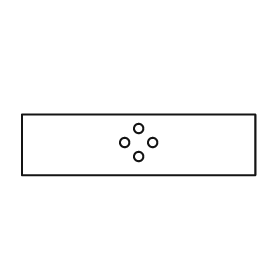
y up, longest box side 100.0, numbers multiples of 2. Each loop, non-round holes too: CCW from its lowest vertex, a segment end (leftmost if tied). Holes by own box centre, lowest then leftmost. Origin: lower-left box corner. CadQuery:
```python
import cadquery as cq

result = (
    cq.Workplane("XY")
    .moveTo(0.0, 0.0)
    .lineTo(100.0, 0.0)
    .lineTo(100.0, 26.0)
    .lineTo(0.0, 26.0)
    .close()
    .moveTo(50.0, 8.0)
    .circle(2.0)
    .moveTo(44.0, 14.0)
    .circle(2.0)
    .moveTo(56.0, 14.0)
    .circle(2.0)
    .moveTo(50.0, 20.0)
    .circle(2.0)
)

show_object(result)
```